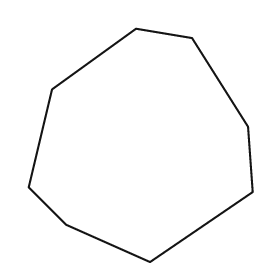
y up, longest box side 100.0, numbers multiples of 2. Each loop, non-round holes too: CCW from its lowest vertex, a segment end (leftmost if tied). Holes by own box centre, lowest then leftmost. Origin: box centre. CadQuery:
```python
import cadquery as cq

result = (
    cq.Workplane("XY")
    .moveTo(4.0, -50.0)
    .lineTo(48.0, -20.0)
    .lineTo(46.0, 8.0)
    .lineTo(22.0, 46.0)
    .lineTo(-2.0, 50.0)
    .lineTo(-38.0, 24.0)
    .lineTo(-48.0, -18.0)
    .lineTo(-32.0, -34.0)
    .close()
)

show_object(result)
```